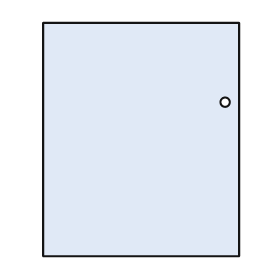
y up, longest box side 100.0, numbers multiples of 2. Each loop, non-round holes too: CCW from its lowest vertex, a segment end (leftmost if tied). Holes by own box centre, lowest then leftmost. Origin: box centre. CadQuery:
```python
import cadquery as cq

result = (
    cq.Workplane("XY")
    .moveTo(-42.0, -50.0)
    .lineTo(42.0, -50.0)
    .lineTo(42.0, 50.0)
    .lineTo(-42.0, 50.0)
    .close()
    .moveTo(36.0, 16.0)
    .circle(2.0)
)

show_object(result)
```